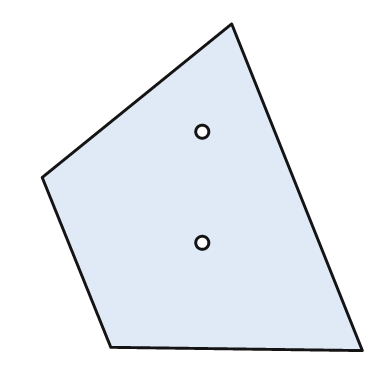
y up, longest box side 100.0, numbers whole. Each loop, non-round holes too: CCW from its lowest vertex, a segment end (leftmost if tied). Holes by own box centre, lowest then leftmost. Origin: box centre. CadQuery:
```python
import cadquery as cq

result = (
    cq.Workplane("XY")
    .moveTo(49.0, -50.0)
    .lineTo(9.0, 50.0)
    .lineTo(-49.0, 3.0)
    .lineTo(-28.0, -49.0)
    .close()
    .moveTo(0.0, -17.0)
    .circle(2.0)
    .moveTo(0.0, 17.0)
    .circle(2.0)
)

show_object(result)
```